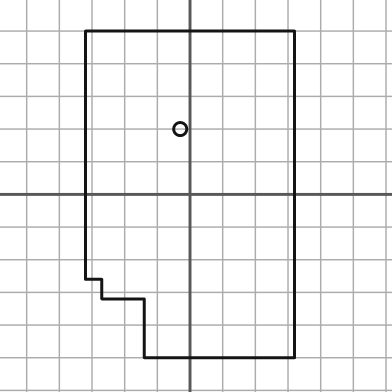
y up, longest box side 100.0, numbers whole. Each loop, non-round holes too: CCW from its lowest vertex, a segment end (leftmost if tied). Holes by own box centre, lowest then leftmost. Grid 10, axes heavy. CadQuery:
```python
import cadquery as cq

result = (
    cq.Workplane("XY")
    .moveTo(-14.0, -50.0)
    .lineTo(32.0, -50.0)
    .lineTo(32.0, 50.0)
    .lineTo(-32.0, 50.0)
    .lineTo(-32.0, -26.0)
    .lineTo(-27.0, -26.0)
    .lineTo(-27.0, -32.0)
    .lineTo(-14.0, -32.0)
    .close()
    .moveTo(-3.0, 20.0)
    .circle(2.0)
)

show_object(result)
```